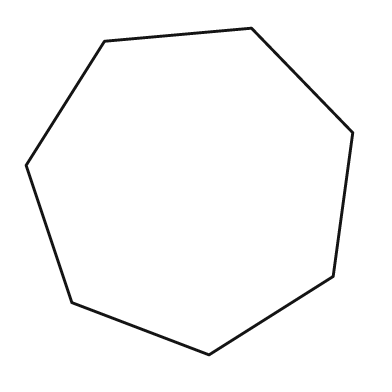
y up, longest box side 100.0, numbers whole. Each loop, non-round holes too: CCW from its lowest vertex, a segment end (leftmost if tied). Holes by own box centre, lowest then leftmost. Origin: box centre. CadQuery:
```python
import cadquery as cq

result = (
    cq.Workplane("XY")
    .moveTo(6.0, -50.0)
    .lineTo(44.0, -26.0)
    .lineTo(50.0, 18.0)
    .lineTo(19.0, 50.0)
    .lineTo(-26.0, 46.0)
    .lineTo(-50.0, 8.0)
    .lineTo(-36.0, -34.0)
    .close()
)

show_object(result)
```